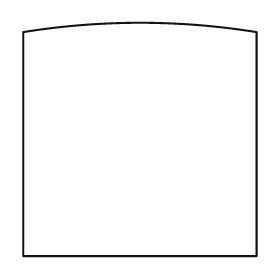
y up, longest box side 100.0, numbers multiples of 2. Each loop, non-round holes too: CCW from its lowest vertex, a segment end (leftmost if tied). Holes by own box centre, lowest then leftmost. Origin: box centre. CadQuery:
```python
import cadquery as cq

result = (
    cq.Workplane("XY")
    .moveTo(-50.0, -50.0)
    .lineTo(50.0, -50.0)
    .lineTo(50.0, 46.0)
    .threePointArc((0.0, 50.0), (-50.0, 46.0))
    .close()
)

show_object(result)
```